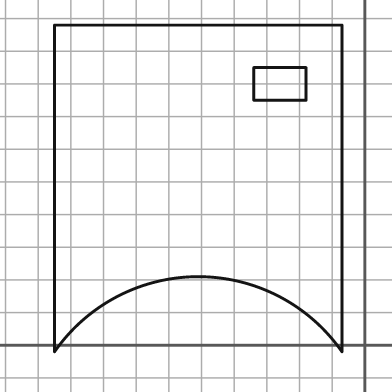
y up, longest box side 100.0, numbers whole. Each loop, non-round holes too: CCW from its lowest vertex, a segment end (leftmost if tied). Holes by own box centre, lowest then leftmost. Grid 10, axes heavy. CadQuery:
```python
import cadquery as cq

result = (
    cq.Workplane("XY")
    .moveTo(-95.0, -2.0)
    .threePointArc((-51.0, 21.0), (-7.0, -2.0))
    .lineTo(-7.0, 98.0)
    .lineTo(-95.0, 98.0)
    .close()
    .moveTo(-34.0, 75.0)
    .lineTo(-18.0, 75.0)
    .lineTo(-18.0, 85.0)
    .lineTo(-34.0, 85.0)
    .close()
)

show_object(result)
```